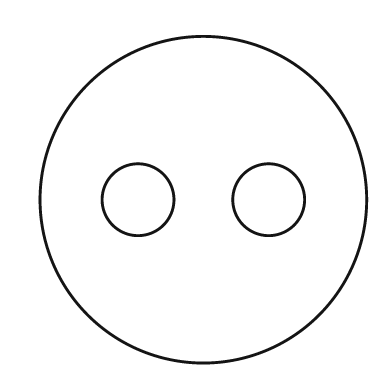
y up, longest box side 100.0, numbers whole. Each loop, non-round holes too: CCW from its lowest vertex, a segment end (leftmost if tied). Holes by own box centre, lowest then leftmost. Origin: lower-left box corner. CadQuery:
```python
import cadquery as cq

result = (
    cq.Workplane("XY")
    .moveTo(50.0, 50.0)
    .circle(50.0)
    .moveTo(30.0, 50.0)
    .circle(11.0)
    .moveTo(70.0, 50.0)
    .circle(11.0)
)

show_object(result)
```